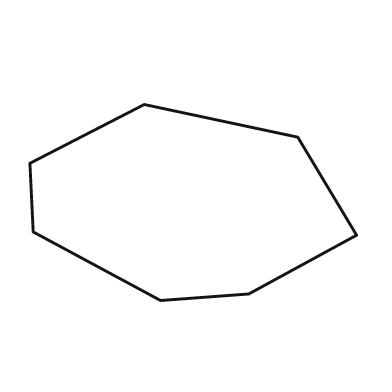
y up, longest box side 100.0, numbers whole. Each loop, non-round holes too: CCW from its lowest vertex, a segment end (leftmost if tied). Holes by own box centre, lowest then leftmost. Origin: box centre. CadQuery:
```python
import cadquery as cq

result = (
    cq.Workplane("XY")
    .moveTo(-10.0, -30.0)
    .lineTo(17.0, -28.0)
    .lineTo(50.0, -10.0)
    .lineTo(32.0, 20.0)
    .lineTo(-15.0, 30.0)
    .lineTo(-50.0, 12.0)
    .lineTo(-49.0, -9.0)
    .close()
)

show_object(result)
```